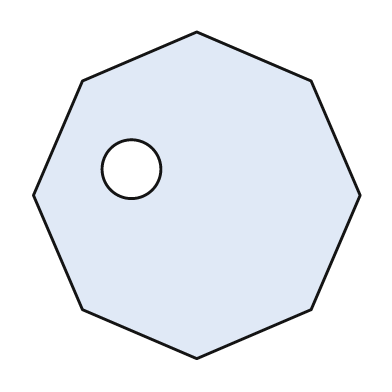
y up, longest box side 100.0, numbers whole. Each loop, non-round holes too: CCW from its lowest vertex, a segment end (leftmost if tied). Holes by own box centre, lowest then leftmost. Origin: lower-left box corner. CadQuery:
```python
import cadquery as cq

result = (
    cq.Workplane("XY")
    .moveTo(50.0, 0.0)
    .lineTo(85.0, 15.0)
    .lineTo(100.0, 50.0)
    .lineTo(85.0, 85.0)
    .lineTo(50.0, 100.0)
    .lineTo(15.0, 85.0)
    .lineTo(0.0, 50.0)
    .lineTo(15.0, 15.0)
    .close()
    .moveTo(30.0, 58.0)
    .circle(9.0)
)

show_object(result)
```